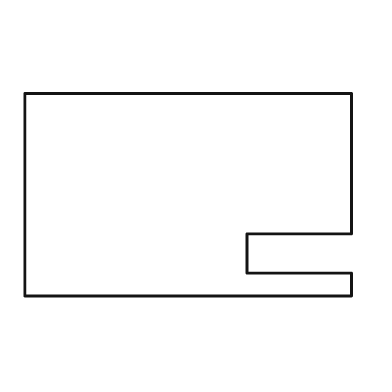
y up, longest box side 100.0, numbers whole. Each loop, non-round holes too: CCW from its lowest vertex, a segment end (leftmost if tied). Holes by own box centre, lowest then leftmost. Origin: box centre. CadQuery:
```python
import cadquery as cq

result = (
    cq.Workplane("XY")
    .moveTo(-50.0, -31.0)
    .lineTo(50.0, -31.0)
    .lineTo(50.0, -24.0)
    .lineTo(18.0, -24.0)
    .lineTo(18.0, -12.0)
    .lineTo(50.0, -12.0)
    .lineTo(50.0, 31.0)
    .lineTo(-50.0, 31.0)
    .close()
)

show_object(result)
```